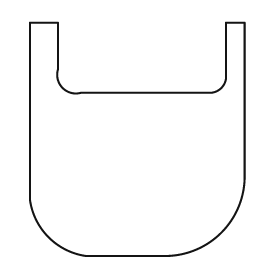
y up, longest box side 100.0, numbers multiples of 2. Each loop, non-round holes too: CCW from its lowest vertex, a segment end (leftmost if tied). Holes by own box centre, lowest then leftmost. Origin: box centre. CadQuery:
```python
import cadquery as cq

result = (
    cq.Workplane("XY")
    .moveTo(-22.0, -50.0)
    .lineTo(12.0, -50.0)
    .threePointArc((36.0, -40.0), (46.0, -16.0))
    .lineTo(46.0, 50.0)
    .lineTo(38.0, 50.0)
    .lineTo(38.0, 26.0)
    .threePointArc((36.0, 22.0), (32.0, 20.0))
    .lineTo(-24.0, 20.0)
    .threePointArc((-32.0, 22.0), (-34.0, 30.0))
    .lineTo(-34.0, 50.0)
    .lineTo(-46.0, 50.0)
    .lineTo(-46.0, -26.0)
    .threePointArc((-38.0, -42.0), (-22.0, -50.0))
    .close()
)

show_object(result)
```